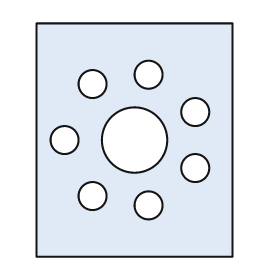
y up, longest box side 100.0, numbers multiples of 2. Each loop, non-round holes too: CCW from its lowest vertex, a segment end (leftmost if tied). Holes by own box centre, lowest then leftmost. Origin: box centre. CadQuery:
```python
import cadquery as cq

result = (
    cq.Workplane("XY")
    .moveTo(-42.0, -50.0)
    .lineTo(42.0, -50.0)
    .lineTo(42.0, 50.0)
    .lineTo(-42.0, 50.0)
    .close()
    .moveTo(6.0, -28.0)
    .circle(6.0)
    .moveTo(-18.0, -24.0)
    .circle(6.0)
    .moveTo(26.0, -12.0)
    .circle(6.0)
    .moveTo(-30.0, 0.0)
    .circle(6.0)
    .moveTo(0.0, 0.0)
    .circle(14.0)
    .moveTo(26.0, 12.0)
    .circle(6.0)
    .moveTo(-18.0, 24.0)
    .circle(6.0)
    .moveTo(6.0, 28.0)
    .circle(6.0)
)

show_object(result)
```